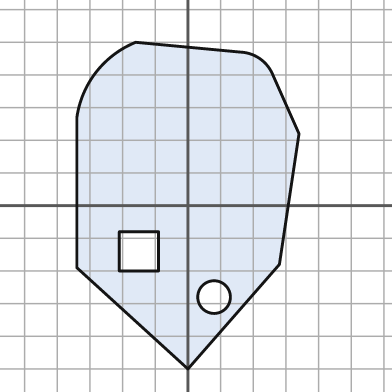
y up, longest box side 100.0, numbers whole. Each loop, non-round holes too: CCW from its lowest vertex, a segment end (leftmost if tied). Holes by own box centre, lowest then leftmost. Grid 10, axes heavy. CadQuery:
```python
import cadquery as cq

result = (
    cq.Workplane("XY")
    .moveTo(0.0, -50.0)
    .lineTo(28.0, -18.0)
    .lineTo(34.0, 22.0)
    .lineTo(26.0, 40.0)
    .threePointArc((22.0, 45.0), (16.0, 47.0))
    .lineTo(-16.0, 50.0)
    .threePointArc((-28.0, 41.0), (-34.0, 27.0))
    .lineTo(-34.0, -19.0)
    .close()
    .moveTo(8.0, -28.0)
    .circle(5.0)
    .moveTo(-21.0, -20.0)
    .lineTo(-9.0, -20.0)
    .lineTo(-9.0, -8.0)
    .lineTo(-21.0, -8.0)
    .close()
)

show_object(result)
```